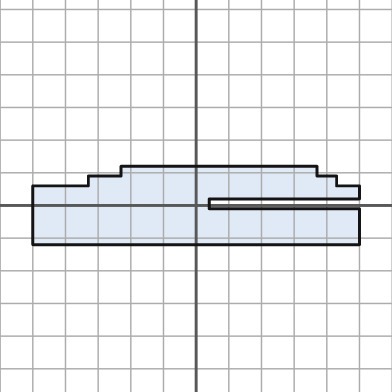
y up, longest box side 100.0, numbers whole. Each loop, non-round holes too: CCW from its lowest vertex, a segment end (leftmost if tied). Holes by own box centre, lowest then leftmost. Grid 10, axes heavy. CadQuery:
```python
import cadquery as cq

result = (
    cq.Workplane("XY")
    .moveTo(-50.0, -12.0)
    .lineTo(50.0, -12.0)
    .lineTo(50.0, -1.0)
    .lineTo(4.0, -1.0)
    .lineTo(4.0, 2.0)
    .lineTo(50.0, 2.0)
    .lineTo(50.0, 6.0)
    .lineTo(43.0, 6.0)
    .lineTo(43.0, 9.0)
    .lineTo(37.0, 9.0)
    .lineTo(37.0, 12.0)
    .lineTo(-23.0, 12.0)
    .lineTo(-23.0, 9.0)
    .lineTo(-33.0, 9.0)
    .lineTo(-33.0, 6.0)
    .lineTo(-50.0, 6.0)
    .close()
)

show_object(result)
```